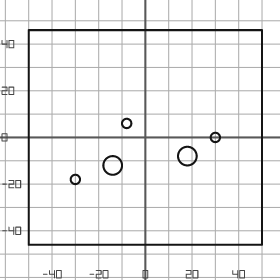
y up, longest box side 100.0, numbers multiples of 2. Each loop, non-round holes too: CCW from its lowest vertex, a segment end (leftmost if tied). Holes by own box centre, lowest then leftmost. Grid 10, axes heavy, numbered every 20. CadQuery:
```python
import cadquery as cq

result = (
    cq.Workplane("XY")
    .moveTo(-50.0, -46.0)
    .lineTo(50.0, -46.0)
    .lineTo(50.0, 46.0)
    .lineTo(-50.0, 46.0)
    .close()
    .moveTo(-30.0, -18.0)
    .circle(2.0)
    .moveTo(-14.0, -12.0)
    .circle(4.0)
    .moveTo(18.0, -8.0)
    .circle(4.0)
    .moveTo(30.0, 0.0)
    .circle(2.0)
    .moveTo(-8.0, 6.0)
    .circle(2.0)
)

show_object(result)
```